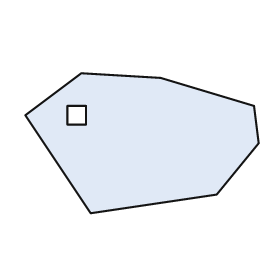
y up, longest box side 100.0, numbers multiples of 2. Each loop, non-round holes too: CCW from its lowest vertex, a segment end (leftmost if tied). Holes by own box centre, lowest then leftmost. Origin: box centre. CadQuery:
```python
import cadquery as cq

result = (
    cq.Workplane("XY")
    .moveTo(-22.0, -30.0)
    .lineTo(32.0, -22.0)
    .lineTo(50.0, 0.0)
    .lineTo(48.0, 16.0)
    .lineTo(8.0, 28.0)
    .lineTo(-26.0, 30.0)
    .lineTo(-50.0, 12.0)
    .close()
    .moveTo(-32.0, 8.0)
    .lineTo(-24.0, 8.0)
    .lineTo(-24.0, 16.0)
    .lineTo(-32.0, 16.0)
    .close()
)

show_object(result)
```